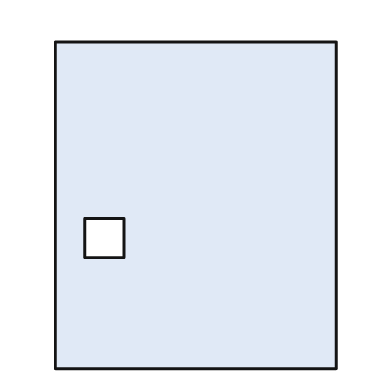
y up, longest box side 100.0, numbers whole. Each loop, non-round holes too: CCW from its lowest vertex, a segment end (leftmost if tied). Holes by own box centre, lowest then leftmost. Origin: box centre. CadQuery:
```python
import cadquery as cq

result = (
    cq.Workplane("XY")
    .moveTo(-43.0, -50.0)
    .lineTo(43.0, -50.0)
    .lineTo(43.0, 50.0)
    .lineTo(-43.0, 50.0)
    .close()
    .moveTo(-34.0, -16.0)
    .lineTo(-22.0, -16.0)
    .lineTo(-22.0, -4.0)
    .lineTo(-34.0, -4.0)
    .close()
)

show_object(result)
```